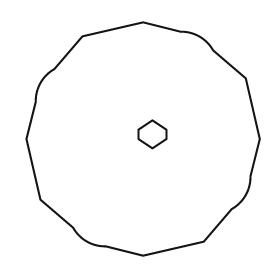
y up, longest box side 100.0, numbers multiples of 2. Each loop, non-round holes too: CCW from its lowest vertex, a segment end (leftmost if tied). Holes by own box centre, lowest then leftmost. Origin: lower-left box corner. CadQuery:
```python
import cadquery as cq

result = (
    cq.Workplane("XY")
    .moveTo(50.0, 0.0)
    .lineTo(76.0, 6.0)
    .lineTo(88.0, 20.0)
    .threePointArc((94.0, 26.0), (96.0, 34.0))
    .lineTo(100.0, 50.0)
    .lineTo(94.0, 76.0)
    .lineTo(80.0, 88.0)
    .threePointArc((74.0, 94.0), (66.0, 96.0))
    .lineTo(50.0, 100.0)
    .lineTo(24.0, 94.0)
    .lineTo(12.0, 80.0)
    .threePointArc((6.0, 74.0), (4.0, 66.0))
    .lineTo(0.0, 50.0)
    .lineTo(6.0, 24.0)
    .lineTo(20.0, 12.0)
    .threePointArc((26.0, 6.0), (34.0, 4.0))
    .close()
    .moveTo(54.0, 46.0)
    .lineTo(60.0, 50.0)
    .lineTo(60.0, 54.0)
    .lineTo(54.0, 58.0)
    .lineTo(48.0, 54.0)
    .lineTo(48.0, 50.0)
    .close()
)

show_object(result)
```